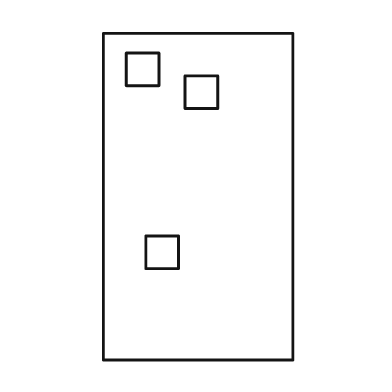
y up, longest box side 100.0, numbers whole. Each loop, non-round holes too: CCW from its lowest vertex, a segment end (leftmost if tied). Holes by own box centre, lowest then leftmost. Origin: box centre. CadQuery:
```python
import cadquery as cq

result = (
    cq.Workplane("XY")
    .moveTo(-29.0, -50.0)
    .lineTo(29.0, -50.0)
    .lineTo(29.0, 50.0)
    .lineTo(-29.0, 50.0)
    .close()
    .moveTo(-16.0, -22.0)
    .lineTo(-6.0, -22.0)
    .lineTo(-6.0, -12.0)
    .lineTo(-16.0, -12.0)
    .close()
    .moveTo(-4.0, 27.0)
    .lineTo(6.0, 27.0)
    .lineTo(6.0, 37.0)
    .lineTo(-4.0, 37.0)
    .close()
    .moveTo(-22.0, 34.0)
    .lineTo(-12.0, 34.0)
    .lineTo(-12.0, 44.0)
    .lineTo(-22.0, 44.0)
    .close()
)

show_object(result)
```